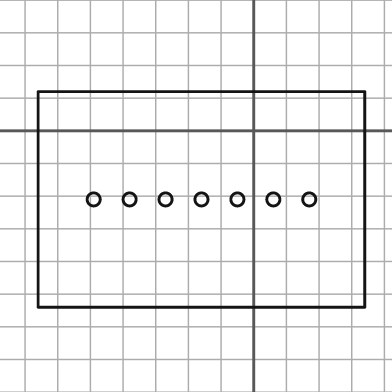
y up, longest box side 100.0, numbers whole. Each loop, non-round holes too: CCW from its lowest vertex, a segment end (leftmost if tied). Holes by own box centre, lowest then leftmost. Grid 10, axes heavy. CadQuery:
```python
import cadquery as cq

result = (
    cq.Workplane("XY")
    .moveTo(-66.0, -54.0)
    .lineTo(34.0, -54.0)
    .lineTo(34.0, 12.0)
    .lineTo(-66.0, 12.0)
    .close()
    .moveTo(-49.0, -21.0)
    .circle(2.0)
    .moveTo(-38.0, -21.0)
    .circle(2.0)
    .moveTo(-27.0, -21.0)
    .circle(2.0)
    .moveTo(-16.0, -21.0)
    .circle(2.0)
    .moveTo(-5.0, -21.0)
    .circle(2.0)
    .moveTo(6.0, -21.0)
    .circle(2.0)
    .moveTo(17.0, -21.0)
    .circle(2.0)
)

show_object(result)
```